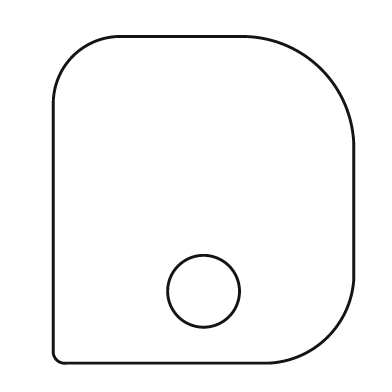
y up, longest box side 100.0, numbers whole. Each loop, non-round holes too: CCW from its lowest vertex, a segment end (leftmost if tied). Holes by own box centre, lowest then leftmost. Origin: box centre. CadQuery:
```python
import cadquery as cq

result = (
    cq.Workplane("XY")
    .moveTo(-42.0, -50.0)
    .lineTo(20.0, -50.0)
    .threePointArc((38.0, -42.0), (46.0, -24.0))
    .lineTo(46.0, 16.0)
    .threePointArc((36.0, 40.0), (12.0, 50.0))
    .lineTo(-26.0, 50.0)
    .threePointArc((-40.0, 44.0), (-46.0, 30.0))
    .lineTo(-46.0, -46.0)
    .threePointArc((-45.0, -49.0), (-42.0, -50.0))
    .close()
    .moveTo(0.0, -28.0)
    .circle(11.0)
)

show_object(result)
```